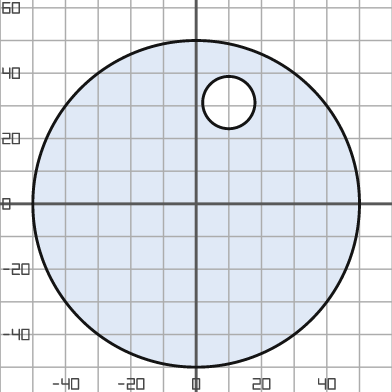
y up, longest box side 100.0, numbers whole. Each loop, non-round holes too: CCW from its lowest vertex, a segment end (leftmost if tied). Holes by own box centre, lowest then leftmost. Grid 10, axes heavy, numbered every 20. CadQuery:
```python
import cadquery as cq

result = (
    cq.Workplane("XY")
    .moveTo(0.0, 0.0)
    .circle(50.0)
    .moveTo(10.0, 31.0)
    .circle(8.0)
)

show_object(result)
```